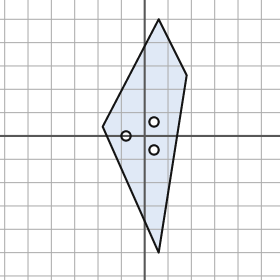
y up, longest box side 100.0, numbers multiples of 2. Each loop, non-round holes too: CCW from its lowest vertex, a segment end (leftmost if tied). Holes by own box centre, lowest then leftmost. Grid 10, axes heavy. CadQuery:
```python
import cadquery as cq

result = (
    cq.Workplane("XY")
    .moveTo(6.0, -50.0)
    .lineTo(18.0, 26.0)
    .lineTo(6.0, 50.0)
    .lineTo(-18.0, 4.0)
    .close()
    .moveTo(4.0, -6.0)
    .circle(2.0)
    .moveTo(-8.0, 0.0)
    .circle(2.0)
    .moveTo(4.0, 6.0)
    .circle(2.0)
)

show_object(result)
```